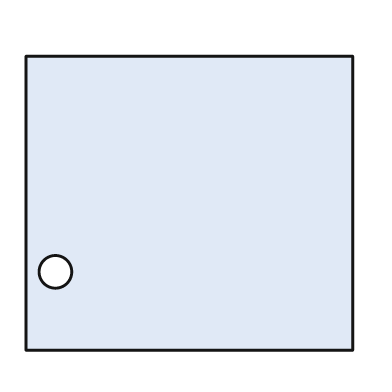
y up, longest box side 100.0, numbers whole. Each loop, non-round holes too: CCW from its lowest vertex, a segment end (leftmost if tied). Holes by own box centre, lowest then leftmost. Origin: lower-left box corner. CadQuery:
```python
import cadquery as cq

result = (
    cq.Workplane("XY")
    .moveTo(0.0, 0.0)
    .lineTo(100.0, 0.0)
    .lineTo(100.0, 90.0)
    .lineTo(0.0, 90.0)
    .close()
    .moveTo(9.0, 24.0)
    .circle(5.0)
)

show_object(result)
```